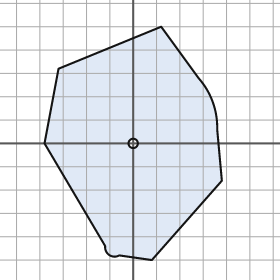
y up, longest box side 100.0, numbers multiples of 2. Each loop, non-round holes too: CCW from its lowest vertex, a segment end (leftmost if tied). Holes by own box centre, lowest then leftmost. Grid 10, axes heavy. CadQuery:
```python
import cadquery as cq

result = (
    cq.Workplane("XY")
    .moveTo(8.0, -50.0)
    .lineTo(38.0, -16.0)
    .lineTo(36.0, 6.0)
    .threePointArc((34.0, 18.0), (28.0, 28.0))
    .lineTo(12.0, 50.0)
    .lineTo(-32.0, 32.0)
    .lineTo(-38.0, 0.0)
    .lineTo(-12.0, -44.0)
    .threePointArc((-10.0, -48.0), (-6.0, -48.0))
    .close()
    .moveTo(0.0, 0.0)
    .circle(2.0)
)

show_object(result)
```